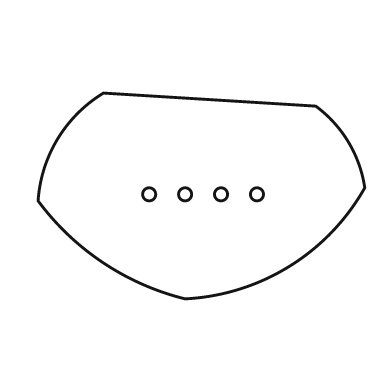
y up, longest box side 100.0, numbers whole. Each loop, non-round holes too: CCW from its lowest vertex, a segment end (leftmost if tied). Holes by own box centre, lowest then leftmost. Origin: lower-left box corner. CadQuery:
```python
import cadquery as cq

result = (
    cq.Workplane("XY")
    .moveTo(45.0, 0.0)
    .threePointArc((77.0, 10.0), (100.0, 34.0))
    .threePointArc((95.0, 48.0), (85.0, 59.0))
    .lineTo(20.0, 63.0)
    .threePointArc((6.0, 49.0), (0.0, 30.0))
    .threePointArc((20.0, 11.0), (45.0, 0.0))
    .close()
    .moveTo(34.0, 32.0)
    .circle(2.0)
    .moveTo(45.0, 32.0)
    .circle(2.0)
    .moveTo(56.0, 32.0)
    .circle(2.0)
    .moveTo(67.0, 32.0)
    .circle(2.0)
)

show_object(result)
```